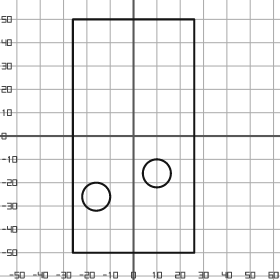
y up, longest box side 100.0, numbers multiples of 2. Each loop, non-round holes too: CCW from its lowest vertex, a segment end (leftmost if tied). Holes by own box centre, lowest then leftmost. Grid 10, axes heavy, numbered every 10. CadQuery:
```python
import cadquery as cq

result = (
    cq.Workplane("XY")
    .moveTo(-26.0, -50.0)
    .lineTo(26.0, -50.0)
    .lineTo(26.0, 50.0)
    .lineTo(-26.0, 50.0)
    .close()
    .moveTo(-16.0, -26.0)
    .circle(6.0)
    .moveTo(10.0, -16.0)
    .circle(6.0)
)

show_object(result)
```